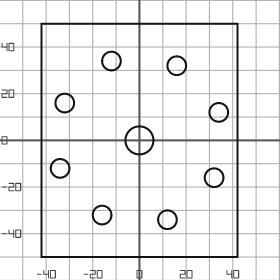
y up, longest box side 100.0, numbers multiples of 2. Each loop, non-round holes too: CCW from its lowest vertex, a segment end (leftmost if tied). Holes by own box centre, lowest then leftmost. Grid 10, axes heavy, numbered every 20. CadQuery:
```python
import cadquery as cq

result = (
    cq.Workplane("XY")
    .moveTo(-42.0, -50.0)
    .lineTo(42.0, -50.0)
    .lineTo(42.0, 50.0)
    .lineTo(-42.0, 50.0)
    .close()
    .moveTo(12.0, -34.0)
    .circle(4.0)
    .moveTo(-16.0, -32.0)
    .circle(4.0)
    .moveTo(32.0, -16.0)
    .circle(4.0)
    .moveTo(-34.0, -12.0)
    .circle(4.0)
    .moveTo(0.0, 0.0)
    .circle(6.0)
    .moveTo(34.0, 12.0)
    .circle(4.0)
    .moveTo(-32.0, 16.0)
    .circle(4.0)
    .moveTo(16.0, 32.0)
    .circle(4.0)
    .moveTo(-12.0, 34.0)
    .circle(4.0)
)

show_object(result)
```